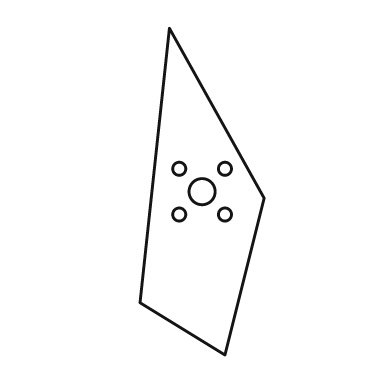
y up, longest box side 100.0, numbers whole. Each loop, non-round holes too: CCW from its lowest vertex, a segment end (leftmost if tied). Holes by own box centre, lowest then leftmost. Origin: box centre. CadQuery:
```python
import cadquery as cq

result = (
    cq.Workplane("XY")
    .moveTo(7.0, -50.0)
    .lineTo(19.0, -2.0)
    .lineTo(-10.0, 50.0)
    .lineTo(-19.0, -34.0)
    .close()
    .moveTo(-7.0, -7.0)
    .circle(2.0)
    .moveTo(7.0, -7.0)
    .circle(2.0)
    .moveTo(0.0, 0.0)
    .circle(4.0)
    .moveTo(-7.0, 7.0)
    .circle(2.0)
    .moveTo(7.0, 7.0)
    .circle(2.0)
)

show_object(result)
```